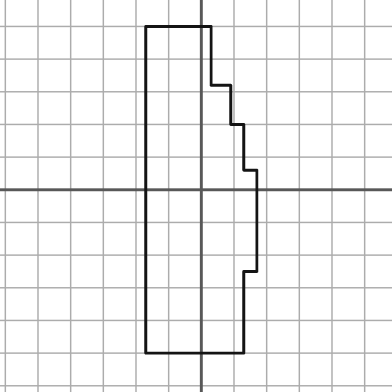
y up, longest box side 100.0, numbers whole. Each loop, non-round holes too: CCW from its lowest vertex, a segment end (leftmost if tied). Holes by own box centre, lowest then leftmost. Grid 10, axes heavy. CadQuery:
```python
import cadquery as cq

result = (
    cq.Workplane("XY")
    .moveTo(-17.0, -50.0)
    .lineTo(13.0, -50.0)
    .lineTo(13.0, -25.0)
    .lineTo(17.0, -25.0)
    .lineTo(17.0, 6.0)
    .lineTo(13.0, 6.0)
    .lineTo(13.0, 20.0)
    .lineTo(9.0, 20.0)
    .lineTo(9.0, 32.0)
    .lineTo(3.0, 32.0)
    .lineTo(3.0, 50.0)
    .lineTo(-17.0, 50.0)
    .close()
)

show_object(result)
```